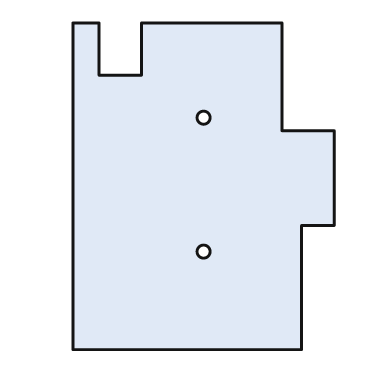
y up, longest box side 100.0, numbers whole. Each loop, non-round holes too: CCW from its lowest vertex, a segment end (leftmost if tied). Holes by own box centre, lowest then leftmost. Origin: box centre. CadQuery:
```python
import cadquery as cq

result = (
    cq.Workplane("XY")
    .moveTo(-40.0, -50.0)
    .lineTo(30.0, -50.0)
    .lineTo(30.0, -12.0)
    .lineTo(40.0, -12.0)
    .lineTo(40.0, 17.0)
    .lineTo(24.0, 17.0)
    .lineTo(24.0, 50.0)
    .lineTo(-19.0, 50.0)
    .lineTo(-19.0, 34.0)
    .lineTo(-32.0, 34.0)
    .lineTo(-32.0, 50.0)
    .lineTo(-40.0, 50.0)
    .close()
    .moveTo(0.0, -20.0)
    .circle(2.0)
    .moveTo(0.0, 21.0)
    .circle(2.0)
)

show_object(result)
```